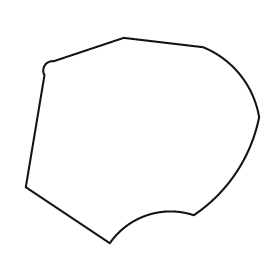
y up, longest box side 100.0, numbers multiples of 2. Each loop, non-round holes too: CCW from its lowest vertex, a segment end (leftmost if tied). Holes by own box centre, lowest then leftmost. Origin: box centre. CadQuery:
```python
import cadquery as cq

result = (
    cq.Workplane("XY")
    .moveTo(-14.0, -44.0)
    .threePointArc((2.0, -32.0), (22.0, -32.0))
    .threePointArc((40.0, -14.0), (50.0, 10.0))
    .threePointArc((42.0, 28.0), (26.0, 40.0))
    .lineTo(-8.0, 44.0)
    .lineTo(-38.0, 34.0)
    .threePointArc((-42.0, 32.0), (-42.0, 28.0))
    .lineTo(-50.0, -20.0)
    .close()
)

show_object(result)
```